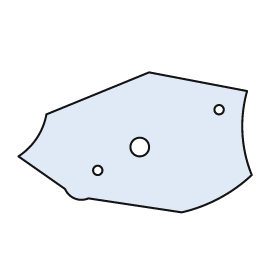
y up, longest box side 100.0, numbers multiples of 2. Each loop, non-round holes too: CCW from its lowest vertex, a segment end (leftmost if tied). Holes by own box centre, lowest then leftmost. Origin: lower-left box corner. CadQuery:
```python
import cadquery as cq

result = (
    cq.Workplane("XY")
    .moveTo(70.0, 0.0)
    .threePointArc((86.0, 6.0), (100.0, 16.0))
    .threePointArc((96.0, 34.0), (98.0, 52.0))
    .lineTo(56.0, 60.0)
    .lineTo(12.0, 42.0)
    .threePointArc((8.0, 32.0), (0.0, 24.0))
    .lineTo(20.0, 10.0)
    .threePointArc((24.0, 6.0), (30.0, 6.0))
    .close()
    .moveTo(34.0, 18.0)
    .circle(2.0)
    .moveTo(52.0, 28.0)
    .circle(4.0)
    .moveTo(86.0, 44.0)
    .circle(2.0)
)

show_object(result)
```